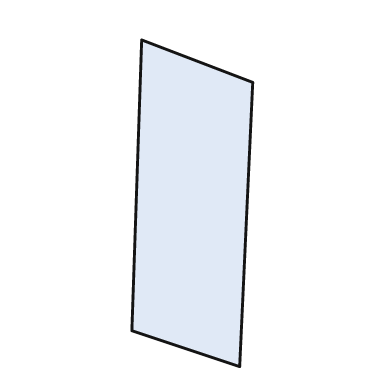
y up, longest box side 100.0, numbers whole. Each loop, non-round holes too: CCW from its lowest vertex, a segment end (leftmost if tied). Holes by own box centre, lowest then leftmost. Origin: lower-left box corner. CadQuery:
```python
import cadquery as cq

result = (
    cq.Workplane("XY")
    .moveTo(33.0, 0.0)
    .lineTo(37.0, 87.0)
    .lineTo(3.0, 100.0)
    .lineTo(0.0, 11.0)
    .close()
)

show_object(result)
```